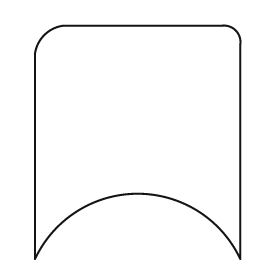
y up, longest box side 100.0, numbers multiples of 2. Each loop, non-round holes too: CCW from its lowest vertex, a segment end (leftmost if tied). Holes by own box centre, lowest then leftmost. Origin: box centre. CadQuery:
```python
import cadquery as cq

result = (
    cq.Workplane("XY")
    .moveTo(-44.0, -50.0)
    .threePointArc((0.0, -22.0), (44.0, -50.0))
    .lineTo(44.0, 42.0)
    .threePointArc((42.0, 48.0), (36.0, 50.0))
    .lineTo(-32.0, 50.0)
    .threePointArc((-40.0, 46.0), (-44.0, 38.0))
    .close()
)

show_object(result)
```